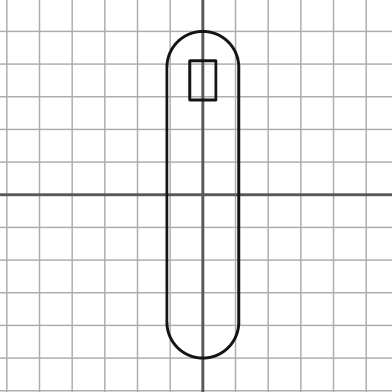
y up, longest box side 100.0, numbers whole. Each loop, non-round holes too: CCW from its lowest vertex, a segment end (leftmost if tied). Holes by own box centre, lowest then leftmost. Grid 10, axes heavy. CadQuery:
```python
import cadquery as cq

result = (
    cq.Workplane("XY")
    .moveTo(-11.0, -39.0)
    .threePointArc((0.0, -50.0), (11.0, -39.0))
    .lineTo(11.0, 39.0)
    .threePointArc((0.0, 50.0), (-11.0, 39.0))
    .close()
    .moveTo(-4.0, 29.0)
    .lineTo(4.0, 29.0)
    .lineTo(4.0, 41.0)
    .lineTo(-4.0, 41.0)
    .close()
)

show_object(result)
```